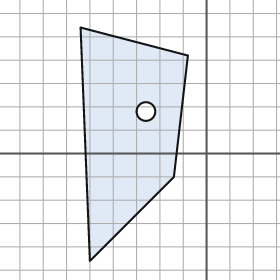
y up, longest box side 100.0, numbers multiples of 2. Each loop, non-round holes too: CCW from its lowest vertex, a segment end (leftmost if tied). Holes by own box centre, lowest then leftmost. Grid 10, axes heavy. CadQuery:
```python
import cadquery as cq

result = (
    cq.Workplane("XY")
    .moveTo(-50.0, -46.0)
    .lineTo(-14.0, -10.0)
    .lineTo(-8.0, 42.0)
    .lineTo(-54.0, 54.0)
    .close()
    .moveTo(-26.0, 18.0)
    .circle(4.0)
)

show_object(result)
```